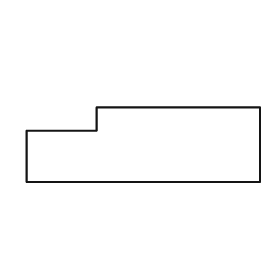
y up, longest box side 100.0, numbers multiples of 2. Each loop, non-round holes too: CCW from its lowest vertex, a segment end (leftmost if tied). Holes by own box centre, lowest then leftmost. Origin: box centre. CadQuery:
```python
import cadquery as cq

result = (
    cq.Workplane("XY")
    .moveTo(-50.0, -16.0)
    .lineTo(50.0, -16.0)
    .lineTo(50.0, 16.0)
    .lineTo(-20.0, 16.0)
    .lineTo(-20.0, 6.0)
    .lineTo(-50.0, 6.0)
    .close()
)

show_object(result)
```